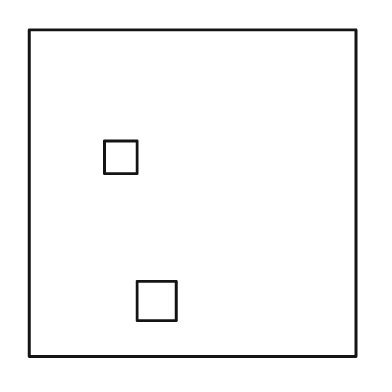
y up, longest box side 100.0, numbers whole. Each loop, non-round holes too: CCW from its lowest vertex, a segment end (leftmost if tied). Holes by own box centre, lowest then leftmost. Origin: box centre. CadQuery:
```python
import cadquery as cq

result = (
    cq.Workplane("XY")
    .moveTo(-50.0, -50.0)
    .lineTo(50.0, -50.0)
    .lineTo(50.0, 50.0)
    .lineTo(-50.0, 50.0)
    .close()
    .moveTo(-17.0, -39.0)
    .lineTo(-5.0, -39.0)
    .lineTo(-5.0, -27.0)
    .lineTo(-17.0, -27.0)
    .close()
    .moveTo(-27.0, 6.0)
    .lineTo(-17.0, 6.0)
    .lineTo(-17.0, 16.0)
    .lineTo(-27.0, 16.0)
    .close()
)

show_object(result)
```